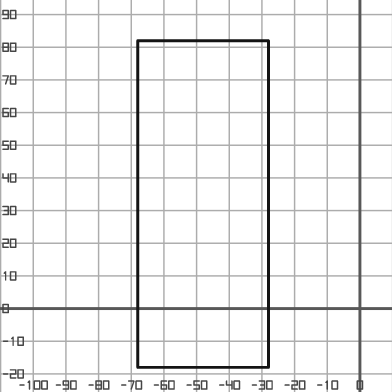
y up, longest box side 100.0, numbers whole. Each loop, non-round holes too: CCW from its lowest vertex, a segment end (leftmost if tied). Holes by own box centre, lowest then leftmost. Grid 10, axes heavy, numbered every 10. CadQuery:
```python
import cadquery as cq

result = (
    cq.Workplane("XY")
    .moveTo(-68.0, -18.0)
    .lineTo(-28.0, -18.0)
    .lineTo(-28.0, 82.0)
    .lineTo(-68.0, 82.0)
    .close()
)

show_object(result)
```